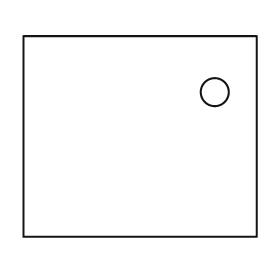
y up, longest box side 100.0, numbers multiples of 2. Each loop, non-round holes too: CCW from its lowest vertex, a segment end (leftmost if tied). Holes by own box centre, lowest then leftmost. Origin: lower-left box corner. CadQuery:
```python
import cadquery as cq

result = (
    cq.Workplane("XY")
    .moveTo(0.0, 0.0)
    .lineTo(100.0, 0.0)
    .lineTo(100.0, 86.0)
    .lineTo(0.0, 86.0)
    .close()
    .moveTo(82.0, 62.0)
    .circle(6.0)
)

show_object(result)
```